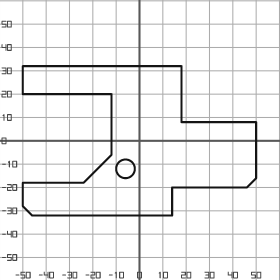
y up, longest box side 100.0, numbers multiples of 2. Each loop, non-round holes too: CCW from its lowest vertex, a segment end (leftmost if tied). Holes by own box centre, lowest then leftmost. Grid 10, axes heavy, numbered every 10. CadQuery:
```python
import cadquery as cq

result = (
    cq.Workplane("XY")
    .moveTo(-46.0, -32.0)
    .lineTo(14.0, -32.0)
    .lineTo(14.0, -20.0)
    .lineTo(46.0, -20.0)
    .lineTo(50.0, -16.0)
    .lineTo(50.0, 8.0)
    .lineTo(18.0, 8.0)
    .lineTo(18.0, 32.0)
    .lineTo(-50.0, 32.0)
    .lineTo(-50.0, 20.0)
    .lineTo(-12.0, 20.0)
    .lineTo(-12.0, -6.0)
    .lineTo(-24.0, -18.0)
    .lineTo(-50.0, -18.0)
    .lineTo(-50.0, -28.0)
    .close()
    .moveTo(-6.0, -12.0)
    .circle(4.0)
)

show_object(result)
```